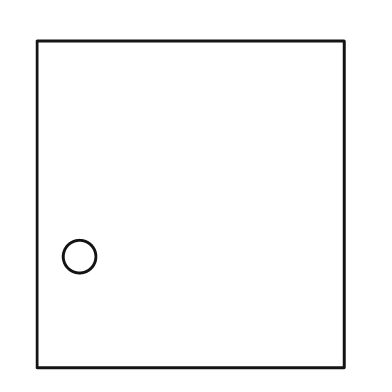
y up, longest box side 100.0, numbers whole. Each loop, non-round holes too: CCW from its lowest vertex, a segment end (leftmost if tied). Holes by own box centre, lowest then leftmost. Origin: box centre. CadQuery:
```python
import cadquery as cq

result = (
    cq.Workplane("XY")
    .moveTo(-47.0, -50.0)
    .lineTo(47.0, -50.0)
    .lineTo(47.0, 50.0)
    .lineTo(-47.0, 50.0)
    .close()
    .moveTo(-34.0, -16.0)
    .circle(5.0)
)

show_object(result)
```